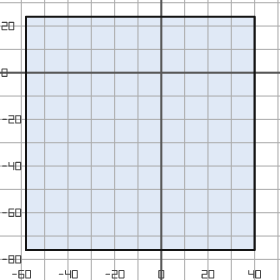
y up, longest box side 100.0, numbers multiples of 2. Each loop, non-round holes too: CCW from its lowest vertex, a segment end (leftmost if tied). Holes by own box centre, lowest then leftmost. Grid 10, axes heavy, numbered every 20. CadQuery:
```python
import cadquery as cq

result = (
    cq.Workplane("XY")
    .moveTo(-58.0, -76.0)
    .lineTo(40.0, -76.0)
    .lineTo(40.0, 24.0)
    .lineTo(-58.0, 24.0)
    .close()
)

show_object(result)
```